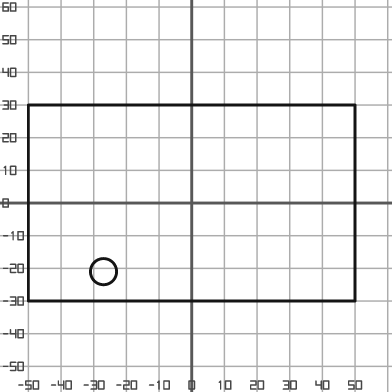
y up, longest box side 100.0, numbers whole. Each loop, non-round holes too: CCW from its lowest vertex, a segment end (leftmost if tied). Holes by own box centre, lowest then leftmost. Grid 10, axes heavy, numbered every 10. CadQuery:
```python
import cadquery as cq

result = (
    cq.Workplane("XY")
    .moveTo(-50.0, -30.0)
    .lineTo(50.0, -30.0)
    .lineTo(50.0, 30.0)
    .lineTo(-50.0, 30.0)
    .close()
    .moveTo(-27.0, -21.0)
    .circle(4.0)
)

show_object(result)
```